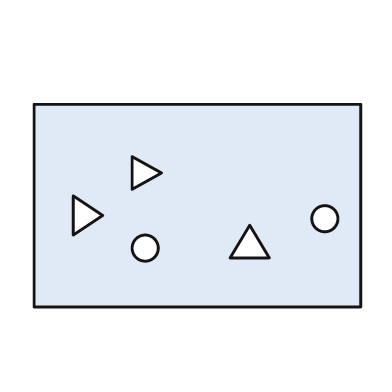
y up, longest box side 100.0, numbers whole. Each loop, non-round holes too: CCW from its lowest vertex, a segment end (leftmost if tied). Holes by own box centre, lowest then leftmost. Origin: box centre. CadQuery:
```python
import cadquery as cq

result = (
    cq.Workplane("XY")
    .moveTo(-50.0, -31.0)
    .lineTo(50.0, -31.0)
    .lineTo(50.0, 31.0)
    .lineTo(-50.0, 31.0)
    .close()
    .moveTo(-16.0, -13.0)
    .circle(4.0)
    .moveTo(10.0, -16.0)
    .lineTo(22.0, -16.0)
    .lineTo(16.0, -6.0)
    .close()
    .moveTo(39.0, -4.0)
    .circle(4.0)
    .moveTo(-38.0, -9.0)
    .lineTo(-29.0, -3.0)
    .lineTo(-38.0, 3.0)
    .close()
    .moveTo(-20.0, 5.0)
    .lineTo(-11.0, 10.0)
    .lineTo(-20.0, 15.0)
    .close()
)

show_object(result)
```